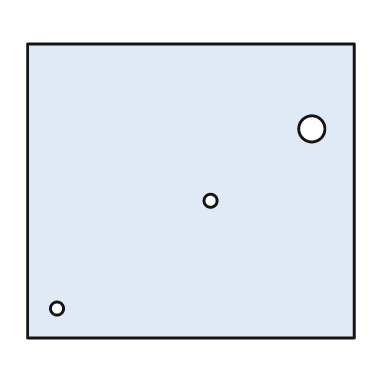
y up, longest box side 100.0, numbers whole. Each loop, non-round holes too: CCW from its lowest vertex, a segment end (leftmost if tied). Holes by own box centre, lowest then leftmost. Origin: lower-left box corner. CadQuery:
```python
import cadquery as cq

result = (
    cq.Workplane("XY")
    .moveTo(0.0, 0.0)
    .lineTo(100.0, 0.0)
    .lineTo(100.0, 90.0)
    .lineTo(0.0, 90.0)
    .close()
    .moveTo(9.0, 9.0)
    .circle(2.0)
    .moveTo(56.0, 42.0)
    .circle(2.0)
    .moveTo(87.0, 64.0)
    .circle(4.0)
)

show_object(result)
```